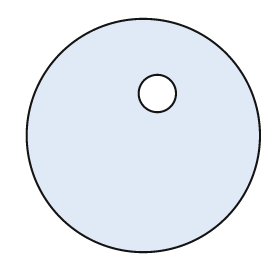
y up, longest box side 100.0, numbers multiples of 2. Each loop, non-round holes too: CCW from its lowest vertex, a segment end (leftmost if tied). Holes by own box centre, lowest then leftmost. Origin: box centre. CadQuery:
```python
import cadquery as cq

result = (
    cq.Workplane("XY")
    .moveTo(0.0, 0.0)
    .circle(50.0)
    .moveTo(6.0, 18.0)
    .circle(8.0)
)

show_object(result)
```